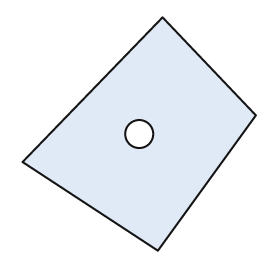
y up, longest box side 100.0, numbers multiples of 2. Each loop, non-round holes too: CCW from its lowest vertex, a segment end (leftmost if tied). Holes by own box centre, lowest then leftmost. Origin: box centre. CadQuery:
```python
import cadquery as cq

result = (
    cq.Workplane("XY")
    .moveTo(8.0, -50.0)
    .lineTo(50.0, 8.0)
    .lineTo(10.0, 50.0)
    .lineTo(-50.0, -12.0)
    .close()
    .moveTo(0.0, 0.0)
    .circle(6.0)
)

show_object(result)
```